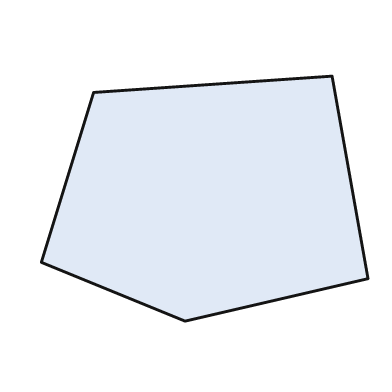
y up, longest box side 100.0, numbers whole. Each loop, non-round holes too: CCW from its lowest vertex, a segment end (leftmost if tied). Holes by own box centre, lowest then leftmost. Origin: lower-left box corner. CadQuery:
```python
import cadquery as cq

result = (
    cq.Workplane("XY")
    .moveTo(44.0, 0.0)
    .lineTo(100.0, 13.0)
    .lineTo(89.0, 75.0)
    .lineTo(16.0, 70.0)
    .lineTo(0.0, 18.0)
    .close()
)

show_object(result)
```